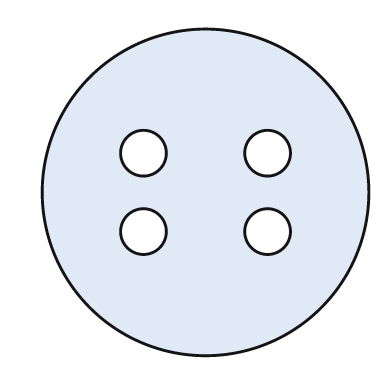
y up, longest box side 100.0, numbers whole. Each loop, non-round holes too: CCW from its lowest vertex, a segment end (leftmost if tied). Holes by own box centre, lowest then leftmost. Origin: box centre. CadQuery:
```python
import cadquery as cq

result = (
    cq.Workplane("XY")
    .moveTo(0.0, 0.0)
    .circle(50.0)
    .moveTo(-19.0, -12.0)
    .circle(7.0)
    .moveTo(19.0, -12.0)
    .circle(7.0)
    .moveTo(-19.0, 12.0)
    .circle(7.0)
    .moveTo(19.0, 12.0)
    .circle(7.0)
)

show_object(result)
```